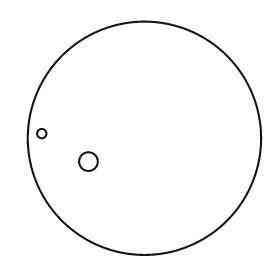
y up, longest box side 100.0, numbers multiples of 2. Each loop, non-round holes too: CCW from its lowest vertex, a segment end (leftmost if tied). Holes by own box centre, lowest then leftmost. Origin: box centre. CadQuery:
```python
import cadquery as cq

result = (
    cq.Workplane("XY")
    .moveTo(0.0, 0.0)
    .circle(50.0)
    .moveTo(-24.0, -10.0)
    .circle(4.0)
    .moveTo(-44.0, 2.0)
    .circle(2.0)
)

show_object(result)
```